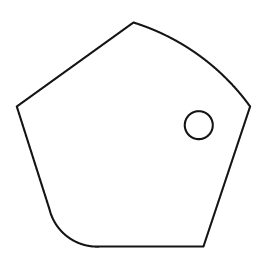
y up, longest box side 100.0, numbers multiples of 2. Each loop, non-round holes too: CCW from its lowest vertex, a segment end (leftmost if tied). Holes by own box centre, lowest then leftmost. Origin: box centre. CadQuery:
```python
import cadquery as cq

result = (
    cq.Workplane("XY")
    .moveTo(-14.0, -48.0)
    .lineTo(30.0, -48.0)
    .lineTo(50.0, 12.0)
    .threePointArc((28.0, 34.0), (0.0, 48.0))
    .lineTo(-50.0, 12.0)
    .lineTo(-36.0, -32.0)
    .threePointArc((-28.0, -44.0), (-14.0, -48.0))
    .close()
    .moveTo(28.0, 4.0)
    .circle(6.0)
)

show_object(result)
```